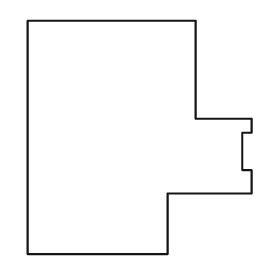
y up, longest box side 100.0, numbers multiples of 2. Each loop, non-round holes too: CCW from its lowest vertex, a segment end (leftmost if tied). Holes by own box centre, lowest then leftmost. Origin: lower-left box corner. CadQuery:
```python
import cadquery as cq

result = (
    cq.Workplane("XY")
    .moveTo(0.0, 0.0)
    .lineTo(60.0, 0.0)
    .lineTo(60.0, 26.0)
    .lineTo(96.0, 26.0)
    .lineTo(96.0, 36.0)
    .lineTo(92.0, 36.0)
    .lineTo(92.0, 52.0)
    .lineTo(96.0, 52.0)
    .lineTo(96.0, 58.0)
    .lineTo(72.0, 58.0)
    .lineTo(72.0, 100.0)
    .lineTo(0.0, 100.0)
    .close()
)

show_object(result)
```